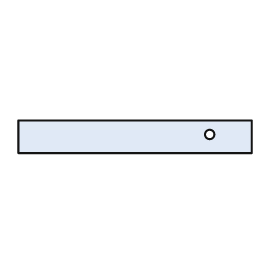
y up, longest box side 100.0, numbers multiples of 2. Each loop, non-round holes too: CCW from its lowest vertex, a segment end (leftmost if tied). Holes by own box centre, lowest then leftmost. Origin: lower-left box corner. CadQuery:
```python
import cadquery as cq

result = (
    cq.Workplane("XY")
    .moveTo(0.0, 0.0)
    .lineTo(100.0, 0.0)
    .lineTo(100.0, 14.0)
    .lineTo(0.0, 14.0)
    .close()
    .moveTo(82.0, 8.0)
    .circle(2.0)
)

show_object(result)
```